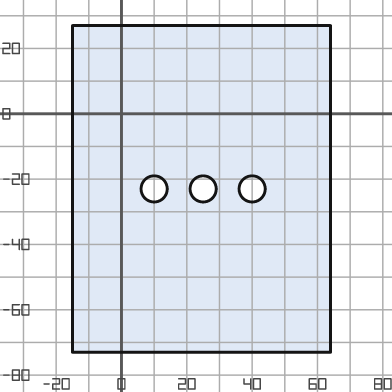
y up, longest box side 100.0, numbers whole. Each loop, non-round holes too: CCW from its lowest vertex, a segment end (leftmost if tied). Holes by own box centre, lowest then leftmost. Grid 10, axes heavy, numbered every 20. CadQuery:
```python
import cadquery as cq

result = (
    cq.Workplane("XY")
    .moveTo(-15.0, -73.0)
    .lineTo(64.0, -73.0)
    .lineTo(64.0, 27.0)
    .lineTo(-15.0, 27.0)
    .close()
    .moveTo(10.0, -23.0)
    .circle(4.0)
    .moveTo(25.0, -23.0)
    .circle(4.0)
    .moveTo(40.0, -23.0)
    .circle(4.0)
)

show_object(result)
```